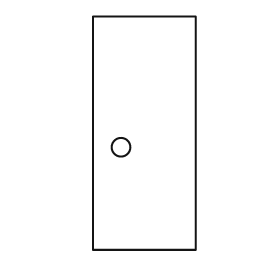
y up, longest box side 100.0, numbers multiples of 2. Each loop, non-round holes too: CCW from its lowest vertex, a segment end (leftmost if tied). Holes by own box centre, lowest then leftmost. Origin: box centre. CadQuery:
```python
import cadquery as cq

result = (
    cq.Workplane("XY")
    .moveTo(-22.0, -50.0)
    .lineTo(22.0, -50.0)
    .lineTo(22.0, 50.0)
    .lineTo(-22.0, 50.0)
    .close()
    .moveTo(-10.0, -6.0)
    .circle(4.0)
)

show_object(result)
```